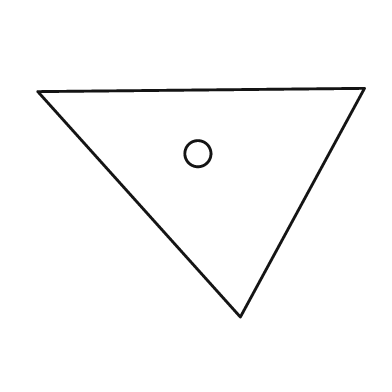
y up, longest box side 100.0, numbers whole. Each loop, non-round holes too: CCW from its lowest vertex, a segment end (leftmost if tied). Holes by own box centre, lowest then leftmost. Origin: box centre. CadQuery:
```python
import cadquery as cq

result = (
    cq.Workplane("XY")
    .moveTo(12.0, -35.0)
    .lineTo(50.0, 35.0)
    .lineTo(-50.0, 34.0)
    .close()
    .moveTo(-1.0, 15.0)
    .circle(4.0)
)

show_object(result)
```